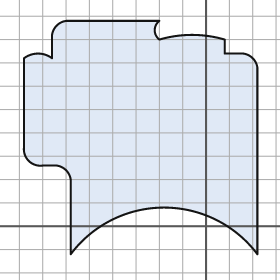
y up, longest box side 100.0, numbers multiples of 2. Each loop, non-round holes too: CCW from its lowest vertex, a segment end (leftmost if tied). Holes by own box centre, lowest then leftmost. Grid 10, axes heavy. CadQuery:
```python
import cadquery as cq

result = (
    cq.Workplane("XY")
    .moveTo(-58.0, -12.0)
    .threePointArc((-18.0, 8.0), (22.0, -12.0))
    .lineTo(22.0, 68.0)
    .threePointArc((20.0, 72.0), (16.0, 74.0))
    .lineTo(8.0, 74.0)
    .lineTo(8.0, 80.0)
    .threePointArc((-6.0, 82.0), (-20.0, 80.0))
    .threePointArc((-22.0, 84.0), (-20.0, 88.0))
    .lineTo(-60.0, 88.0)
    .threePointArc((-64.0, 86.0), (-66.0, 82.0))
    .lineTo(-66.0, 72.0)
    .threePointArc((-72.0, 74.0), (-78.0, 72.0))
    .lineTo(-78.0, 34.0)
    .threePointArc((-76.0, 28.0), (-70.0, 26.0))
    .lineTo(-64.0, 26.0)
    .threePointArc((-60.0, 24.0), (-58.0, 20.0))
    .close()
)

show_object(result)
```